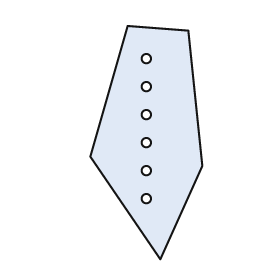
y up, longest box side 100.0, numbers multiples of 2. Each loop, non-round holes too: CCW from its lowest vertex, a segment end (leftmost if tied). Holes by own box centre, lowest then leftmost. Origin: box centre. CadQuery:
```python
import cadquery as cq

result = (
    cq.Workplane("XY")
    .moveTo(6.0, -50.0)
    .lineTo(24.0, -10.0)
    .lineTo(18.0, 48.0)
    .lineTo(-8.0, 50.0)
    .lineTo(-24.0, -6.0)
    .close()
    .moveTo(0.0, -24.0)
    .circle(2.0)
    .moveTo(0.0, -12.0)
    .circle(2.0)
    .moveTo(0.0, 0.0)
    .circle(2.0)
    .moveTo(0.0, 12.0)
    .circle(2.0)
    .moveTo(0.0, 24.0)
    .circle(2.0)
    .moveTo(0.0, 36.0)
    .circle(2.0)
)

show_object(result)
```